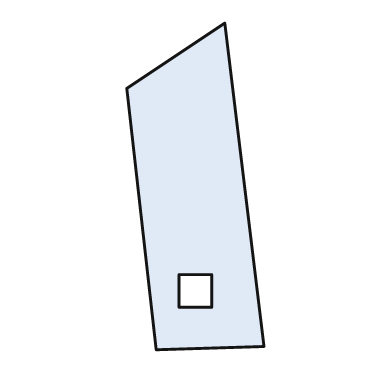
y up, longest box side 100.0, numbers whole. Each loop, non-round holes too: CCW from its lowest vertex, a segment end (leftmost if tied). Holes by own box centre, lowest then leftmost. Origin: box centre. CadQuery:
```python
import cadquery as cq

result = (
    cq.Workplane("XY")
    .moveTo(-12.0, -50.0)
    .lineTo(21.0, -49.0)
    .lineTo(9.0, 50.0)
    .lineTo(-21.0, 30.0)
    .close()
    .moveTo(-5.0, -37.0)
    .lineTo(5.0, -37.0)
    .lineTo(5.0, -27.0)
    .lineTo(-5.0, -27.0)
    .close()
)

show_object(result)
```